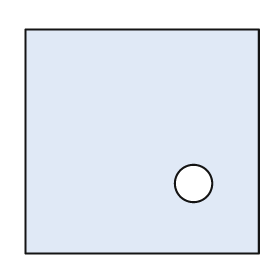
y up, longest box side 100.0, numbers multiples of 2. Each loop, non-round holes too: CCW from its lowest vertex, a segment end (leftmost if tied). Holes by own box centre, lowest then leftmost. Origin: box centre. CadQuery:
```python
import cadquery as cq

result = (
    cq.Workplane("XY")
    .moveTo(-50.0, -48.0)
    .lineTo(50.0, -48.0)
    .lineTo(50.0, 48.0)
    .lineTo(-50.0, 48.0)
    .close()
    .moveTo(22.0, -18.0)
    .circle(8.0)
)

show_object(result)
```